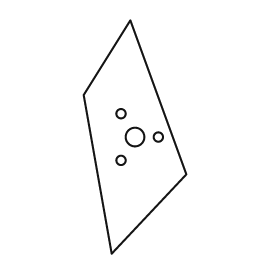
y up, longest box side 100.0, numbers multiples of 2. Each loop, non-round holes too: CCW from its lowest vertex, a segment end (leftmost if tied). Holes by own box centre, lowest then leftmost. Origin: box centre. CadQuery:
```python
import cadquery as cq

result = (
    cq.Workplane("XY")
    .moveTo(-10.0, -50.0)
    .lineTo(22.0, -16.0)
    .lineTo(-2.0, 50.0)
    .lineTo(-22.0, 18.0)
    .close()
    .moveTo(-6.0, -10.0)
    .circle(2.0)
    .moveTo(0.0, 0.0)
    .circle(4.0)
    .moveTo(10.0, 0.0)
    .circle(2.0)
    .moveTo(-6.0, 10.0)
    .circle(2.0)
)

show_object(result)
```